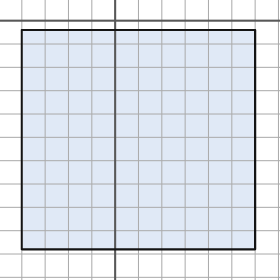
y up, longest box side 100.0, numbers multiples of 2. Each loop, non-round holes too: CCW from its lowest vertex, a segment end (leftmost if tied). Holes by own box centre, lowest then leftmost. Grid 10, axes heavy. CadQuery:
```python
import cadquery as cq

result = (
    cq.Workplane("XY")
    .moveTo(-40.0, -98.0)
    .lineTo(60.0, -98.0)
    .lineTo(60.0, -4.0)
    .lineTo(-40.0, -4.0)
    .close()
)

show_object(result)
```